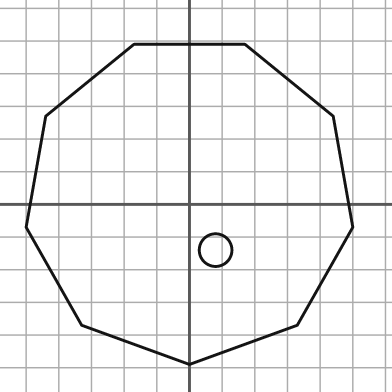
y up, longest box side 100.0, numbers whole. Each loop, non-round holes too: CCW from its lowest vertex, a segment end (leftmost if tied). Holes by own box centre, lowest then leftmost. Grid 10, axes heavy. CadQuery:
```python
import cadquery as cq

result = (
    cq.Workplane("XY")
    .moveTo(0.0, -49.0)
    .lineTo(33.0, -37.0)
    .lineTo(50.0, -7.0)
    .lineTo(44.0, 27.0)
    .lineTo(17.0, 49.0)
    .lineTo(-17.0, 49.0)
    .lineTo(-44.0, 27.0)
    .lineTo(-50.0, -7.0)
    .lineTo(-33.0, -37.0)
    .close()
    .moveTo(8.0, -14.0)
    .circle(5.0)
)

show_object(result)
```